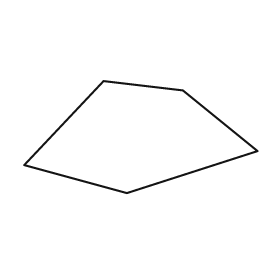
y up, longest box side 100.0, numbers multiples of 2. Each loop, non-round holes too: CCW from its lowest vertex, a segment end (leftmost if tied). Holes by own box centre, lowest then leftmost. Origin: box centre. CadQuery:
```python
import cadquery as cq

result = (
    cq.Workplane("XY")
    .moveTo(-6.0, -24.0)
    .lineTo(50.0, -6.0)
    .lineTo(18.0, 20.0)
    .lineTo(-16.0, 24.0)
    .lineTo(-50.0, -12.0)
    .close()
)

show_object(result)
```